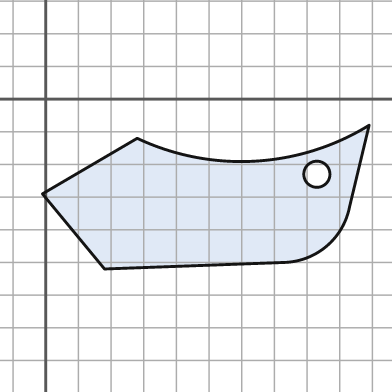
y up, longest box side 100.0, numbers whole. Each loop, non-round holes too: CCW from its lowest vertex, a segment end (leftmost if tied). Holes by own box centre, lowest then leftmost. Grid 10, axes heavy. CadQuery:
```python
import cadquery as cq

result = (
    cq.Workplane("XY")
    .moveTo(18.0, -52.0)
    .lineTo(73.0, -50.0)
    .threePointArc((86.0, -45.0), (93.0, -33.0))
    .lineTo(99.0, -8.0)
    .threePointArc((64.0, -19.0), (28.0, -12.0))
    .lineTo(-1.0, -29.0)
    .close()
    .moveTo(83.0, -23.0)
    .circle(4.0)
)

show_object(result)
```